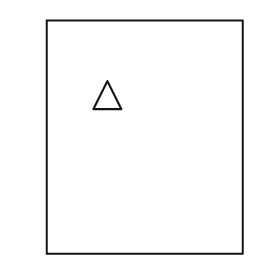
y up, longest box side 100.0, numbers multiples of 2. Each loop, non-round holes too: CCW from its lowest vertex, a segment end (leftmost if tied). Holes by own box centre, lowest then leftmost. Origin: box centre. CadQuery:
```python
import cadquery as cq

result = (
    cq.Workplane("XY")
    .moveTo(-42.0, -50.0)
    .lineTo(42.0, -50.0)
    .lineTo(42.0, 50.0)
    .lineTo(-42.0, 50.0)
    .close()
    .moveTo(-22.0, 12.0)
    .lineTo(-10.0, 12.0)
    .lineTo(-16.0, 24.0)
    .close()
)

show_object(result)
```